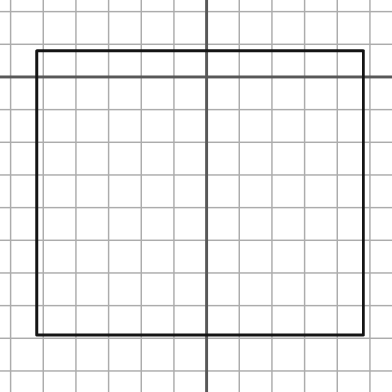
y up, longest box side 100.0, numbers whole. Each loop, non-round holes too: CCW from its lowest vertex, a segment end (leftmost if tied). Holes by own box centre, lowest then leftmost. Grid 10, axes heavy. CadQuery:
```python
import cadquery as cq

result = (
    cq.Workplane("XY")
    .moveTo(-52.0, -79.0)
    .lineTo(48.0, -79.0)
    .lineTo(48.0, 8.0)
    .lineTo(-52.0, 8.0)
    .close()
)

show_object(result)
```